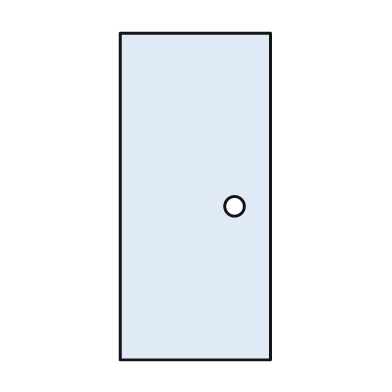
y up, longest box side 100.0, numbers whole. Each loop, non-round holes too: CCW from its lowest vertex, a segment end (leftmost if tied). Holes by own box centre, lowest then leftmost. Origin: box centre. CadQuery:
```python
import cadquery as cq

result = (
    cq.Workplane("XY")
    .moveTo(-23.0, -50.0)
    .lineTo(23.0, -50.0)
    .lineTo(23.0, 50.0)
    .lineTo(-23.0, 50.0)
    .close()
    .moveTo(12.0, -3.0)
    .circle(3.0)
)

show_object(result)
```